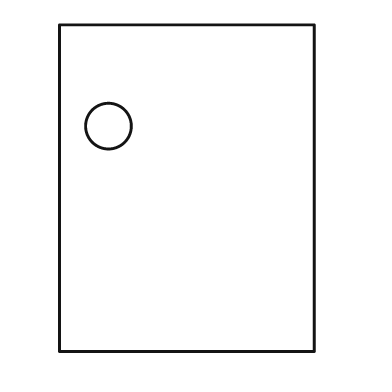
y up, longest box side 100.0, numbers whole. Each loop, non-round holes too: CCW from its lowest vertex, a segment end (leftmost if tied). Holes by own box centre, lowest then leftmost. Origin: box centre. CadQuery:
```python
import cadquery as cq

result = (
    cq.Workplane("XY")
    .moveTo(-39.0, -50.0)
    .lineTo(39.0, -50.0)
    .lineTo(39.0, 50.0)
    .lineTo(-39.0, 50.0)
    .close()
    .moveTo(-24.0, 19.0)
    .circle(7.0)
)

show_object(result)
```